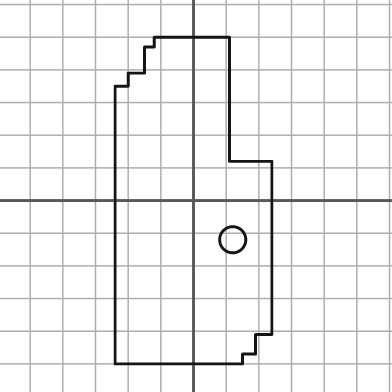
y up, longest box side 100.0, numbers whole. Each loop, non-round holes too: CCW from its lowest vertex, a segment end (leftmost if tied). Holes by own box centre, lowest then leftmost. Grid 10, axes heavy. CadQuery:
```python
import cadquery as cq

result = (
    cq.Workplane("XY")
    .moveTo(-24.0, -50.0)
    .lineTo(15.0, -50.0)
    .lineTo(15.0, -47.0)
    .lineTo(19.0, -47.0)
    .lineTo(19.0, -41.0)
    .lineTo(24.0, -41.0)
    .lineTo(24.0, 12.0)
    .lineTo(11.0, 12.0)
    .lineTo(11.0, 50.0)
    .lineTo(-12.0, 50.0)
    .lineTo(-12.0, 47.0)
    .lineTo(-15.0, 47.0)
    .lineTo(-15.0, 39.0)
    .lineTo(-20.0, 39.0)
    .lineTo(-20.0, 35.0)
    .lineTo(-24.0, 35.0)
    .close()
    .moveTo(12.0, -12.0)
    .circle(4.0)
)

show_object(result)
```